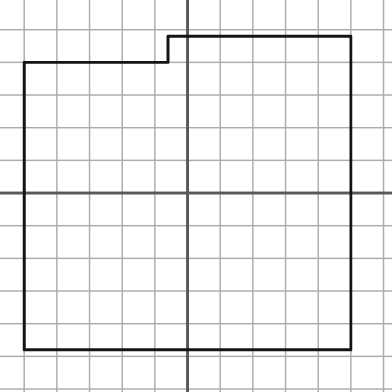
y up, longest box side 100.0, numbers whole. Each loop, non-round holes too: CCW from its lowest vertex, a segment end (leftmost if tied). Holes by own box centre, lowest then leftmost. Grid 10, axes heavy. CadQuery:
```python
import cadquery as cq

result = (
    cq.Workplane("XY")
    .moveTo(-50.0, -48.0)
    .lineTo(50.0, -48.0)
    .lineTo(50.0, 48.0)
    .lineTo(-6.0, 48.0)
    .lineTo(-6.0, 40.0)
    .lineTo(-50.0, 40.0)
    .close()
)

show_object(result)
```